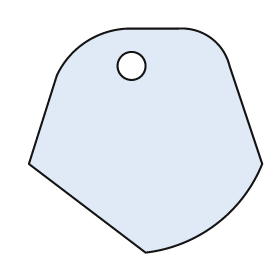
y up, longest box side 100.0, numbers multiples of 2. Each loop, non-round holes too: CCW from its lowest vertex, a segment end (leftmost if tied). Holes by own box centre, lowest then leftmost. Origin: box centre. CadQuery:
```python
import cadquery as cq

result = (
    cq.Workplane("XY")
    .moveTo(0.0, -48.0)
    .threePointArc((30.0, -36.0), (50.0, -10.0))
    .lineTo(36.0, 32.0)
    .threePointArc((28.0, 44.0), (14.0, 48.0))
    .lineTo(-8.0, 48.0)
    .threePointArc((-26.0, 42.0), (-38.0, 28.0))
    .lineTo(-50.0, -10.0)
    .close()
    .moveTo(-6.0, 32.0)
    .circle(6.0)
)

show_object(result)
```